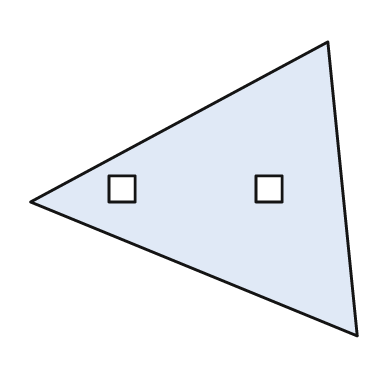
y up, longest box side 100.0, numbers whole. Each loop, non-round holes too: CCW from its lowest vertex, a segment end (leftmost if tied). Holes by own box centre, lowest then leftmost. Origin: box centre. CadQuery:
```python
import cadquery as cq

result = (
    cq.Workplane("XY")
    .moveTo(50.0, -45.0)
    .lineTo(41.0, 45.0)
    .lineTo(-50.0, -4.0)
    .close()
    .moveTo(-26.0, -4.0)
    .lineTo(-18.0, -4.0)
    .lineTo(-18.0, 4.0)
    .lineTo(-26.0, 4.0)
    .close()
    .moveTo(19.0, -4.0)
    .lineTo(27.0, -4.0)
    .lineTo(27.0, 4.0)
    .lineTo(19.0, 4.0)
    .close()
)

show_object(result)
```